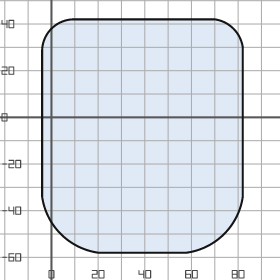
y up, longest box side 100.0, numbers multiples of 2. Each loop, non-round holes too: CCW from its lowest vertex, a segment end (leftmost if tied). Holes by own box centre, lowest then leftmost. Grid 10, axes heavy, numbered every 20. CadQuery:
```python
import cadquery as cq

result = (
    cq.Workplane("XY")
    .moveTo(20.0, -58.0)
    .lineTo(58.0, -58.0)
    .threePointArc((74.0, -50.0), (82.0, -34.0))
    .lineTo(82.0, 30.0)
    .threePointArc((78.0, 38.0), (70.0, 42.0))
    .lineTo(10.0, 42.0)
    .threePointArc((0.0, 38.0), (-4.0, 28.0))
    .lineTo(-4.0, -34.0)
    .threePointArc((4.0, -50.0), (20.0, -58.0))
    .close()
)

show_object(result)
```